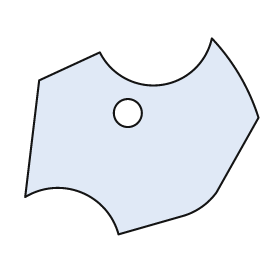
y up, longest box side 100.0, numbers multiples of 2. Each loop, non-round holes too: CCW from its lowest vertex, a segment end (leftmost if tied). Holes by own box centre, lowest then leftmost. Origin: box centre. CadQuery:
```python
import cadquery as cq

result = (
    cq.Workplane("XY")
    .moveTo(-10.0, -42.0)
    .lineTo(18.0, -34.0)
    .threePointArc((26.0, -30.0), (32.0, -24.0))
    .lineTo(50.0, 8.0)
    .threePointArc((42.0, 26.0), (30.0, 42.0))
    .threePointArc((8.0, 22.0), (-18.0, 36.0))
    .lineTo(-44.0, 24.0)
    .lineTo(-50.0, -26.0)
    .threePointArc((-26.0, -24.0), (-10.0, -42.0))
    .close()
    .moveTo(-6.0, 10.0)
    .circle(6.0)
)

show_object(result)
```